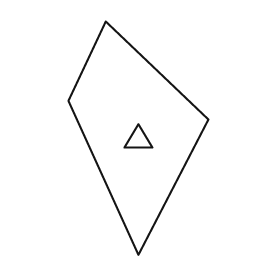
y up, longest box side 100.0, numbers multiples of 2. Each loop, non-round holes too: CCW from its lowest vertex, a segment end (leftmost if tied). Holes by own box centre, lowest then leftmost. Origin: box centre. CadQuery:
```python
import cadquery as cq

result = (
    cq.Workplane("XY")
    .moveTo(0.0, -50.0)
    .lineTo(30.0, 8.0)
    .lineTo(-14.0, 50.0)
    .lineTo(-30.0, 16.0)
    .close()
    .moveTo(-6.0, -4.0)
    .lineTo(6.0, -4.0)
    .lineTo(0.0, 6.0)
    .close()
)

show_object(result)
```